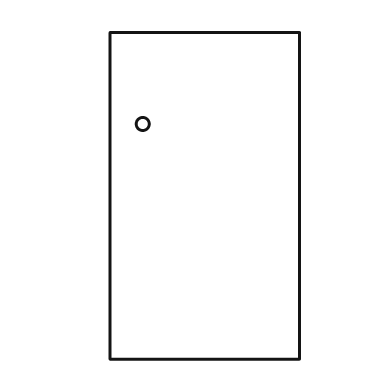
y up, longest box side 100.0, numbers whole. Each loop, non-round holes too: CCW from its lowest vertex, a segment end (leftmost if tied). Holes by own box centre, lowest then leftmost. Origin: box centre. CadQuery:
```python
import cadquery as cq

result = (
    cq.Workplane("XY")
    .moveTo(-29.0, -50.0)
    .lineTo(29.0, -50.0)
    .lineTo(29.0, 50.0)
    .lineTo(-29.0, 50.0)
    .close()
    .moveTo(-19.0, 22.0)
    .circle(2.0)
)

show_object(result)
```